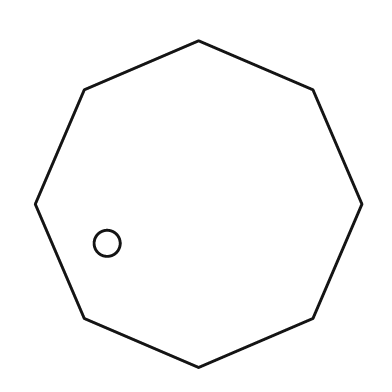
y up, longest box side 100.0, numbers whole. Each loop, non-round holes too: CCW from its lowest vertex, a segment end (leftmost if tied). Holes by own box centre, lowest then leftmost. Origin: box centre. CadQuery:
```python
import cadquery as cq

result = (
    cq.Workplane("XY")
    .moveTo(0.0, -50.0)
    .lineTo(35.0, -35.0)
    .lineTo(50.0, 0.0)
    .lineTo(35.0, 35.0)
    .lineTo(0.0, 50.0)
    .lineTo(-35.0, 35.0)
    .lineTo(-50.0, 0.0)
    .lineTo(-35.0, -35.0)
    .close()
    .moveTo(-28.0, -12.0)
    .circle(4.0)
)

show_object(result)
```